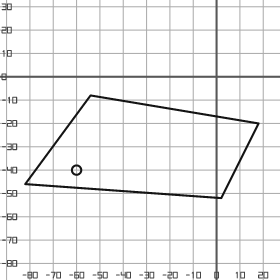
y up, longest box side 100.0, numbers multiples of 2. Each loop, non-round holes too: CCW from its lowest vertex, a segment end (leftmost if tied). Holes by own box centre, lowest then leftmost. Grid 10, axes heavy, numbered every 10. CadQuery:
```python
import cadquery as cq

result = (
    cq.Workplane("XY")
    .moveTo(2.0, -52.0)
    .lineTo(18.0, -20.0)
    .lineTo(-54.0, -8.0)
    .lineTo(-82.0, -46.0)
    .close()
    .moveTo(-60.0, -40.0)
    .circle(2.0)
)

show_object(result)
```